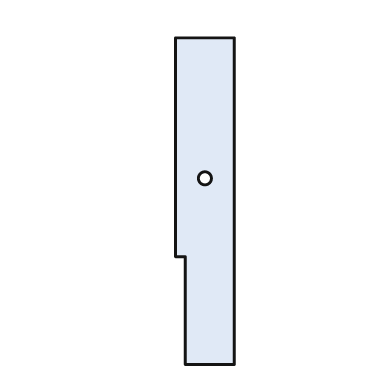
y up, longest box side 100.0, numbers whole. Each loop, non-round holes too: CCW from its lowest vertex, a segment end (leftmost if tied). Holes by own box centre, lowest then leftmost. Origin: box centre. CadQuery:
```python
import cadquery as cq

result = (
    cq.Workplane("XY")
    .moveTo(-6.0, -50.0)
    .lineTo(9.0, -50.0)
    .lineTo(9.0, 50.0)
    .lineTo(-9.0, 50.0)
    .lineTo(-9.0, -17.0)
    .lineTo(-6.0, -17.0)
    .close()
    .moveTo(0.0, 7.0)
    .circle(2.0)
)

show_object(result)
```